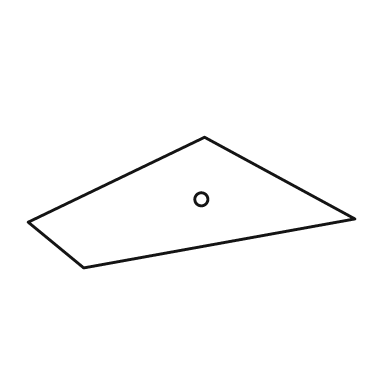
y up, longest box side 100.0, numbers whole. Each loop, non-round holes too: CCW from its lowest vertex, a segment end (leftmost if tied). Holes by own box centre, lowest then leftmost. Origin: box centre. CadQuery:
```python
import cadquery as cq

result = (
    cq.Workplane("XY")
    .moveTo(-33.0, -20.0)
    .lineTo(50.0, -5.0)
    .lineTo(4.0, 20.0)
    .lineTo(-50.0, -6.0)
    .close()
    .moveTo(3.0, 1.0)
    .circle(2.0)
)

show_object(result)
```